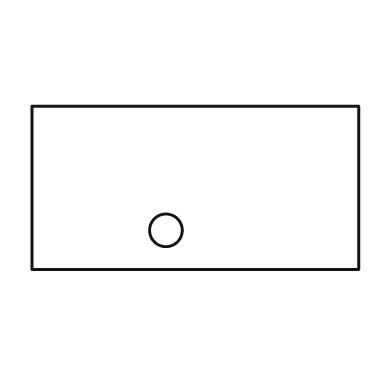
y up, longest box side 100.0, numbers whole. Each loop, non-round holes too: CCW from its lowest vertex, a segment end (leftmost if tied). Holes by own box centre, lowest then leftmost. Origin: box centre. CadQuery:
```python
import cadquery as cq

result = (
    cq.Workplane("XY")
    .moveTo(-50.0, -25.0)
    .lineTo(50.0, -25.0)
    .lineTo(50.0, 25.0)
    .lineTo(-50.0, 25.0)
    .close()
    .moveTo(-9.0, -13.0)
    .circle(5.0)
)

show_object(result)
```